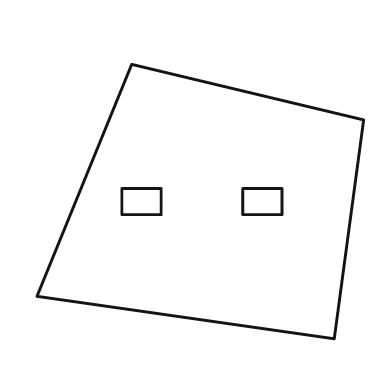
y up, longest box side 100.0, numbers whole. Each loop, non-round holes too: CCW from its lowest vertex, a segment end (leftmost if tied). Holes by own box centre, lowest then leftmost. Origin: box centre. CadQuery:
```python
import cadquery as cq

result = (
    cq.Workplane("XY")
    .moveTo(41.0, -42.0)
    .lineTo(50.0, 25.0)
    .lineTo(-21.0, 42.0)
    .lineTo(-50.0, -29.0)
    .close()
    .moveTo(-24.0, -4.0)
    .lineTo(-12.0, -4.0)
    .lineTo(-12.0, 4.0)
    .lineTo(-24.0, 4.0)
    .close()
    .moveTo(13.0, -4.0)
    .lineTo(25.0, -4.0)
    .lineTo(25.0, 4.0)
    .lineTo(13.0, 4.0)
    .close()
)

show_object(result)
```